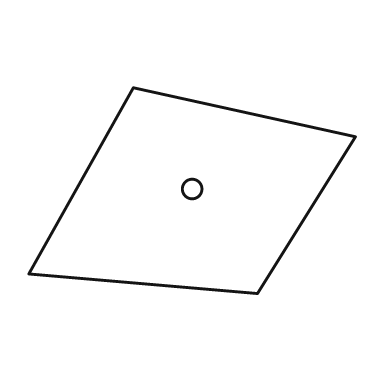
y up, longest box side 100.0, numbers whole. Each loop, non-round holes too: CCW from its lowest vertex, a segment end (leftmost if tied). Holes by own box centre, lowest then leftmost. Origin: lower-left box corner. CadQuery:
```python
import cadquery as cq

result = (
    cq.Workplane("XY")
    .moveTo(70.0, 0.0)
    .lineTo(100.0, 48.0)
    .lineTo(32.0, 63.0)
    .lineTo(0.0, 6.0)
    .close()
    .moveTo(50.0, 32.0)
    .circle(3.0)
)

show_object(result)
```